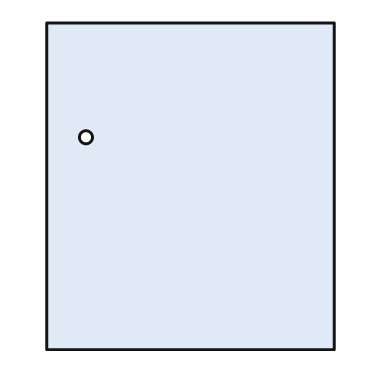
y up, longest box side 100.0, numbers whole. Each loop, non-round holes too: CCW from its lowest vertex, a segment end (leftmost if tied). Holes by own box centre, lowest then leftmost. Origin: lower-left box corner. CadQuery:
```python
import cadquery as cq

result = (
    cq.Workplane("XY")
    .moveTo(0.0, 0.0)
    .lineTo(88.0, 0.0)
    .lineTo(88.0, 100.0)
    .lineTo(0.0, 100.0)
    .close()
    .moveTo(12.0, 65.0)
    .circle(2.0)
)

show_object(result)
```